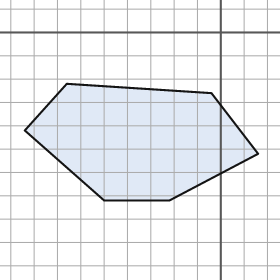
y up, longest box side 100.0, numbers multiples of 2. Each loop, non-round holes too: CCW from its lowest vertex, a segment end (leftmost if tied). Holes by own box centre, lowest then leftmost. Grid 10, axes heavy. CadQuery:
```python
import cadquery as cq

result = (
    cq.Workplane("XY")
    .moveTo(-50.0, -72.0)
    .lineTo(-22.0, -72.0)
    .lineTo(16.0, -52.0)
    .lineTo(-4.0, -26.0)
    .lineTo(-66.0, -22.0)
    .lineTo(-84.0, -42.0)
    .close()
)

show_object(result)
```